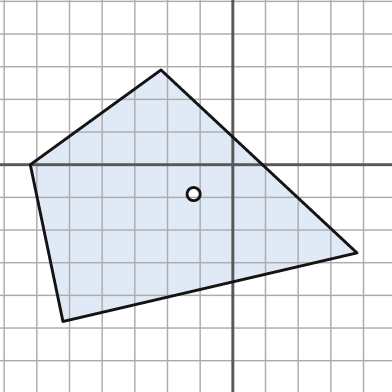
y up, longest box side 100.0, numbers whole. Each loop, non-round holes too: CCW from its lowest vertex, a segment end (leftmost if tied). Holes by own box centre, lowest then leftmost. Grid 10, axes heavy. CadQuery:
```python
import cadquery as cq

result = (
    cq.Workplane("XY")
    .moveTo(-52.0, -48.0)
    .lineTo(38.0, -27.0)
    .lineTo(-22.0, 29.0)
    .lineTo(-62.0, 0.0)
    .close()
    .moveTo(-12.0, -9.0)
    .circle(2.0)
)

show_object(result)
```